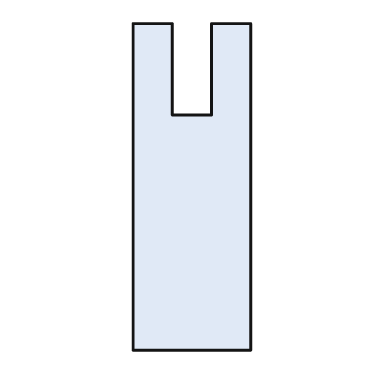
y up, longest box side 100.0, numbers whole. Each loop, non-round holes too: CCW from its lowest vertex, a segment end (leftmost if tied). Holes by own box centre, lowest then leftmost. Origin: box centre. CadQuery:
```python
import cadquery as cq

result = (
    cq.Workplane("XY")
    .moveTo(-18.0, -50.0)
    .lineTo(18.0, -50.0)
    .lineTo(18.0, 50.0)
    .lineTo(6.0, 50.0)
    .lineTo(6.0, 22.0)
    .lineTo(-6.0, 22.0)
    .lineTo(-6.0, 50.0)
    .lineTo(-18.0, 50.0)
    .close()
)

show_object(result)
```